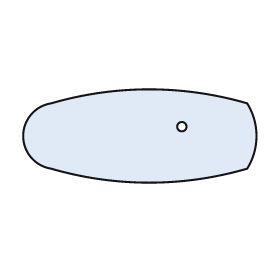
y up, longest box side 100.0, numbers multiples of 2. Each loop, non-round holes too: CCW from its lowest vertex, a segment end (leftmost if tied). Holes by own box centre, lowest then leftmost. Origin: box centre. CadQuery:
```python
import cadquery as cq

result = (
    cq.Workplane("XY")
    .moveTo(-38.0, -14.0)
    .threePointArc((4.0, -20.0), (46.0, -14.0))
    .threePointArc((50.0, 0.0), (46.0, 14.0))
    .threePointArc((4.0, 20.0), (-38.0, 14.0))
    .threePointArc((-50.0, 0.0), (-38.0, -14.0))
    .close()
    .moveTo(18.0, 4.0)
    .circle(2.0)
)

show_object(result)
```